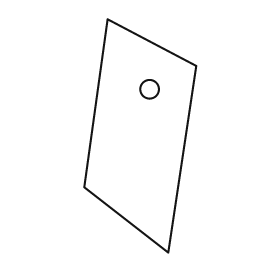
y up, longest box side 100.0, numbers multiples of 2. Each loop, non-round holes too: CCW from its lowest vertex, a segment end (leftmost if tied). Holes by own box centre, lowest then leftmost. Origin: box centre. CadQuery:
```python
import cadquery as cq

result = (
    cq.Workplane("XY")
    .moveTo(12.0, -50.0)
    .lineTo(24.0, 30.0)
    .lineTo(-14.0, 50.0)
    .lineTo(-24.0, -22.0)
    .close()
    .moveTo(4.0, 20.0)
    .circle(4.0)
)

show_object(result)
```